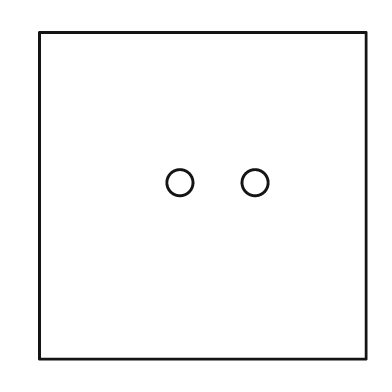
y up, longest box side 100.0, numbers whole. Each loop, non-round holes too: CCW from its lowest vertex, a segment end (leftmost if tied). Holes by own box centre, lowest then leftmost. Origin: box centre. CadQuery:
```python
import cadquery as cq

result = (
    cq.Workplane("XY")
    .moveTo(-50.0, -50.0)
    .lineTo(50.0, -50.0)
    .lineTo(50.0, 50.0)
    .lineTo(-50.0, 50.0)
    .close()
    .moveTo(-7.0, 4.0)
    .circle(4.0)
    .moveTo(16.0, 4.0)
    .circle(4.0)
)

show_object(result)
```